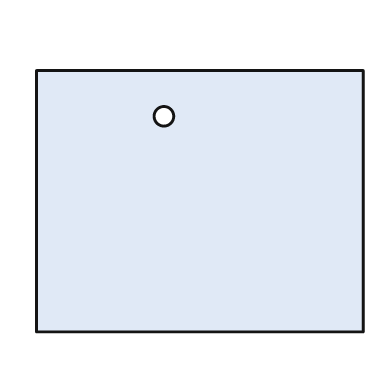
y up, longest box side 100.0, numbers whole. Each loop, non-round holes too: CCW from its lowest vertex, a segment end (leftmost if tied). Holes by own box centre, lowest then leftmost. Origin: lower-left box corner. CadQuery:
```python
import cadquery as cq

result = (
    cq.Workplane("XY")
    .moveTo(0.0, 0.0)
    .lineTo(100.0, 0.0)
    .lineTo(100.0, 80.0)
    .lineTo(0.0, 80.0)
    .close()
    .moveTo(39.0, 66.0)
    .circle(3.0)
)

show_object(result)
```